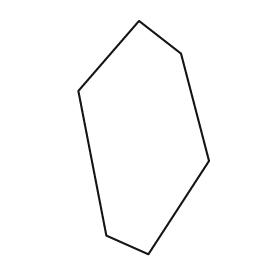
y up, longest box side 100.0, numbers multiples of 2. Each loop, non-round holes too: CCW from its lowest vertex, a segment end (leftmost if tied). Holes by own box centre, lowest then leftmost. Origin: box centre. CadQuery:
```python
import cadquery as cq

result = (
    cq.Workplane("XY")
    .moveTo(2.0, -50.0)
    .lineTo(28.0, -10.0)
    .lineTo(16.0, 36.0)
    .lineTo(-2.0, 50.0)
    .lineTo(-28.0, 20.0)
    .lineTo(-16.0, -42.0)
    .close()
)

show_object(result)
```